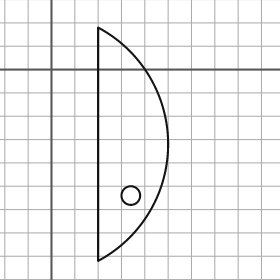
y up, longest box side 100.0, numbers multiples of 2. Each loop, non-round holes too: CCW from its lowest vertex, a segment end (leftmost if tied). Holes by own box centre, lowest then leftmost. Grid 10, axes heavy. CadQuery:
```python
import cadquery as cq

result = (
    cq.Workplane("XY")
    .moveTo(20.0, -82.0)
    .threePointArc((50.0, -32.0), (20.0, 18.0))
    .close()
    .moveTo(34.0, -54.0)
    .circle(4.0)
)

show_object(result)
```